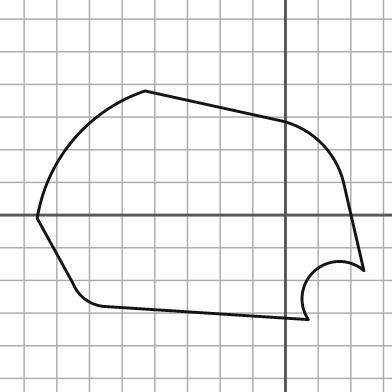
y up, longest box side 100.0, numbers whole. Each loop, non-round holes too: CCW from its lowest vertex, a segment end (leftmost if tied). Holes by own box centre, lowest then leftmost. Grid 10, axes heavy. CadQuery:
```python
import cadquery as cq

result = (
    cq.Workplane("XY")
    .moveTo(7.0, -32.0)
    .threePointArc((9.0, -17.0), (24.0, -17.0))
    .lineTo(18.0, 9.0)
    .threePointArc((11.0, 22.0), (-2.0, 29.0))
    .lineTo(-43.0, 38.0)
    .threePointArc((-65.0, 23.0), (-76.0, -1.0))
    .lineTo(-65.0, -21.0)
    .threePointArc((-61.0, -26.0), (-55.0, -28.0))
    .close()
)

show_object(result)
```